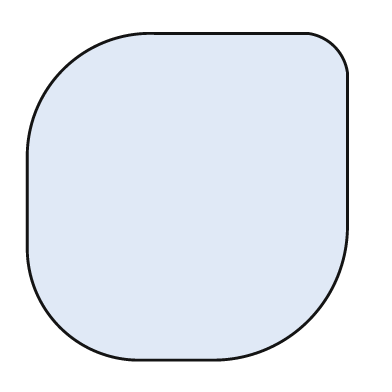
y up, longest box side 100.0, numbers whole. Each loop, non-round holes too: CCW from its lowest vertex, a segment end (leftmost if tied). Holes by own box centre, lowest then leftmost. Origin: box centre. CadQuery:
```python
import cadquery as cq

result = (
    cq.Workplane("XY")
    .moveTo(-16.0, -50.0)
    .lineTo(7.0, -50.0)
    .threePointArc((37.0, -38.0), (49.0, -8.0))
    .lineTo(49.0, 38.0)
    .threePointArc((45.0, 46.0), (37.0, 50.0))
    .lineTo(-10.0, 50.0)
    .threePointArc((-38.0, 39.0), (-49.0, 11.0))
    .lineTo(-49.0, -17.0)
    .threePointArc((-39.0, -40.0), (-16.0, -50.0))
    .close()
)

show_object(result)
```